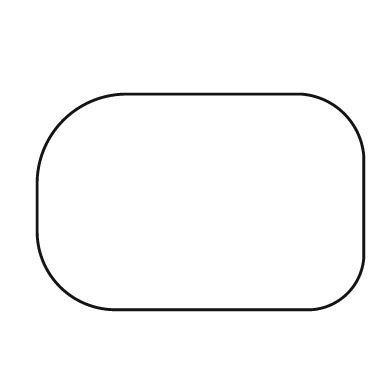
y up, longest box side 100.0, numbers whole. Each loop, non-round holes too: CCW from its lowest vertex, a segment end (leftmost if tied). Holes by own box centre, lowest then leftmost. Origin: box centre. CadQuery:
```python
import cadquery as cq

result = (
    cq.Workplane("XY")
    .moveTo(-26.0, -33.0)
    .lineTo(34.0, -33.0)
    .threePointArc((45.0, -28.0), (50.0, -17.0))
    .lineTo(50.0, 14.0)
    .threePointArc((44.0, 27.0), (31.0, 33.0))
    .lineTo(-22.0, 33.0)
    .threePointArc((-42.0, 25.0), (-50.0, 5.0))
    .lineTo(-50.0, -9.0)
    .threePointArc((-43.0, -26.0), (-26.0, -33.0))
    .close()
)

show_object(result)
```